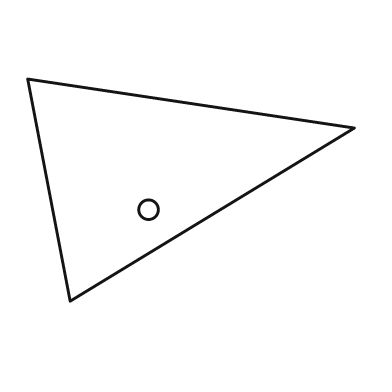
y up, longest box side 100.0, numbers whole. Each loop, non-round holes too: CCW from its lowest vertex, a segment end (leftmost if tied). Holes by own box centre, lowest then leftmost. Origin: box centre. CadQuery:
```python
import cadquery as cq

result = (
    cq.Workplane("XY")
    .moveTo(-37.0, -34.0)
    .lineTo(50.0, 19.0)
    .lineTo(-50.0, 34.0)
    .close()
    .moveTo(-13.0, -6.0)
    .circle(3.0)
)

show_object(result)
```